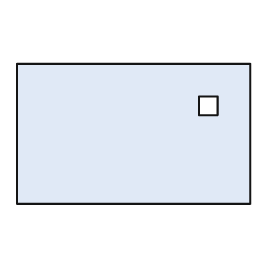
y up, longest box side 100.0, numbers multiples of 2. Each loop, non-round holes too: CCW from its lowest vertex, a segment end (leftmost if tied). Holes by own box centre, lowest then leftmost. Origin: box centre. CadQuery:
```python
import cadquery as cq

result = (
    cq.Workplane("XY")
    .moveTo(-50.0, -30.0)
    .lineTo(50.0, -30.0)
    .lineTo(50.0, 30.0)
    .lineTo(-50.0, 30.0)
    .close()
    .moveTo(28.0, 8.0)
    .lineTo(36.0, 8.0)
    .lineTo(36.0, 16.0)
    .lineTo(28.0, 16.0)
    .close()
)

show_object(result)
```